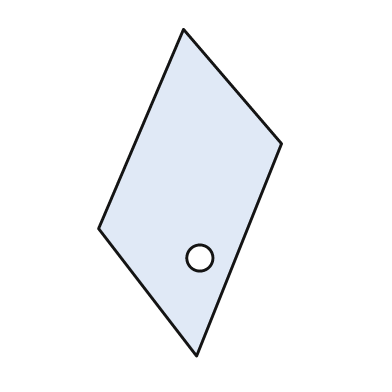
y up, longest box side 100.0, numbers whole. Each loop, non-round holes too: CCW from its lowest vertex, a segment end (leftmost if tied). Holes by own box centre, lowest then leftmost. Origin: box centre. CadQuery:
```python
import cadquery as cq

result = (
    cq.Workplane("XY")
    .moveTo(2.0, -50.0)
    .lineTo(28.0, 15.0)
    .lineTo(-2.0, 50.0)
    .lineTo(-28.0, -11.0)
    .close()
    .moveTo(3.0, -20.0)
    .circle(4.0)
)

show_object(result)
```